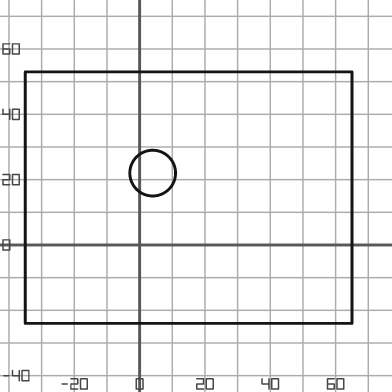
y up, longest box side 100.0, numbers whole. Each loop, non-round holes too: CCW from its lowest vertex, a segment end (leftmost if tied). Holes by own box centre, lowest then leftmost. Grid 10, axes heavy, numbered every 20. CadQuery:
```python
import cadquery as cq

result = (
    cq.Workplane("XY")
    .moveTo(-35.0, -24.0)
    .lineTo(65.0, -24.0)
    .lineTo(65.0, 53.0)
    .lineTo(-35.0, 53.0)
    .close()
    .moveTo(4.0, 22.0)
    .circle(7.0)
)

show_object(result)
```